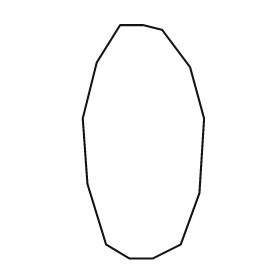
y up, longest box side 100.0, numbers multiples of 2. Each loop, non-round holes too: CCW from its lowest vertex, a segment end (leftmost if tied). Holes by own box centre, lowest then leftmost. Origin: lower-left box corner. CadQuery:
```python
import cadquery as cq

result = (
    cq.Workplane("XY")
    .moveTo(20.0, 0.0)
    .lineTo(30.0, 0.0)
    .lineTo(42.0, 6.0)
    .lineTo(50.0, 28.0)
    .lineTo(52.0, 60.0)
    .lineTo(46.0, 82.0)
    .lineTo(34.0, 98.0)
    .lineTo(26.0, 100.0)
    .lineTo(16.0, 100.0)
    .lineTo(6.0, 84.0)
    .lineTo(0.0, 60.0)
    .lineTo(2.0, 32.0)
    .lineTo(10.0, 6.0)
    .close()
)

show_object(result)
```